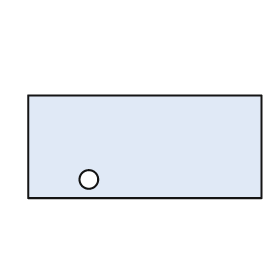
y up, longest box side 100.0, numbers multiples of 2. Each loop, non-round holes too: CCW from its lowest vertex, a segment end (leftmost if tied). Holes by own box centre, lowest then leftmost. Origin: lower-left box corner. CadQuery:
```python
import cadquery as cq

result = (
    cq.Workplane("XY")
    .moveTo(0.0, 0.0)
    .lineTo(100.0, 0.0)
    .lineTo(100.0, 44.0)
    .lineTo(0.0, 44.0)
    .close()
    .moveTo(26.0, 8.0)
    .circle(4.0)
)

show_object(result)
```